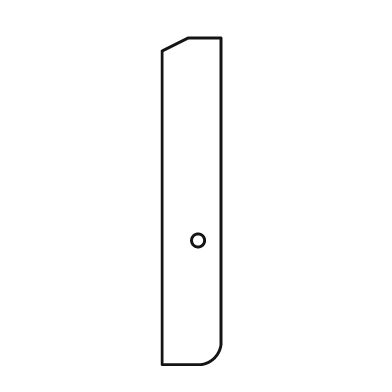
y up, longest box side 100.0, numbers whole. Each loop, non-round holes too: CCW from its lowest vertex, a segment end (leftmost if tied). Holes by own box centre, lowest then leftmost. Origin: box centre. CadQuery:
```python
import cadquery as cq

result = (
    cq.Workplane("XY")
    .moveTo(-9.0, -50.0)
    .lineTo(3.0, -50.0)
    .threePointArc((7.0, -48.0), (9.0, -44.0))
    .lineTo(9.0, 50.0)
    .lineTo(-1.0, 50.0)
    .lineTo(-9.0, 46.0)
    .close()
    .moveTo(2.0, -12.0)
    .circle(2.0)
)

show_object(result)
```